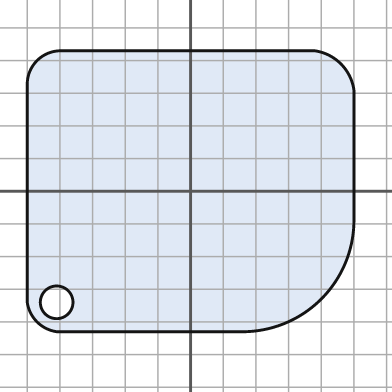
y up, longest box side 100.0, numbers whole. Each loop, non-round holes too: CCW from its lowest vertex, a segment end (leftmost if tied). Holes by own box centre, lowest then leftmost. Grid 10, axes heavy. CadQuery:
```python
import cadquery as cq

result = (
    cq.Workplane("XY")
    .moveTo(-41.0, -43.0)
    .lineTo(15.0, -43.0)
    .threePointArc((40.0, -33.0), (50.0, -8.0))
    .lineTo(50.0, 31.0)
    .threePointArc((46.0, 39.0), (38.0, 43.0))
    .lineTo(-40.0, 43.0)
    .threePointArc((-47.0, 40.0), (-50.0, 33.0))
    .lineTo(-50.0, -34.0)
    .threePointArc((-47.0, -40.0), (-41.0, -43.0))
    .close()
    .moveTo(-41.0, -34.0)
    .circle(5.0)
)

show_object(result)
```